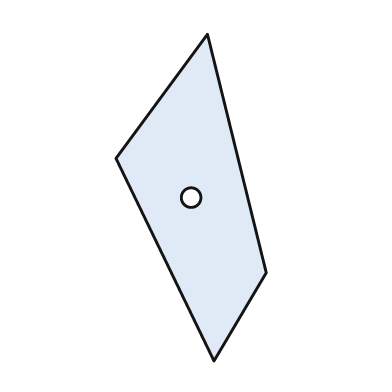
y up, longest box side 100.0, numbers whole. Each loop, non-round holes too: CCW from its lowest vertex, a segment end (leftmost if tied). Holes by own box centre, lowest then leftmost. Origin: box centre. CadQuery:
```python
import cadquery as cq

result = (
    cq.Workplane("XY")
    .moveTo(7.0, -50.0)
    .lineTo(23.0, -23.0)
    .lineTo(5.0, 50.0)
    .lineTo(-23.0, 12.0)
    .close()
    .moveTo(0.0, 0.0)
    .circle(3.0)
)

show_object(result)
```